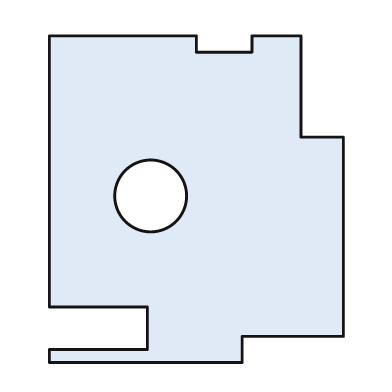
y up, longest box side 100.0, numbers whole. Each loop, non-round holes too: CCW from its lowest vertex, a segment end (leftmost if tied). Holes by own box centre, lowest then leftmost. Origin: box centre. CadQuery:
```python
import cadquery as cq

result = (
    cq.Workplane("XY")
    .moveTo(-45.0, -50.0)
    .lineTo(14.0, -50.0)
    .lineTo(14.0, -42.0)
    .lineTo(45.0, -42.0)
    .lineTo(45.0, 19.0)
    .lineTo(32.0, 19.0)
    .lineTo(32.0, 50.0)
    .lineTo(17.0, 50.0)
    .lineTo(17.0, 45.0)
    .lineTo(0.0, 45.0)
    .lineTo(0.0, 50.0)
    .lineTo(-45.0, 50.0)
    .lineTo(-45.0, -33.0)
    .lineTo(-15.0, -33.0)
    .lineTo(-15.0, -46.0)
    .lineTo(-45.0, -46.0)
    .close()
    .moveTo(-14.0, 1.0)
    .circle(11.0)
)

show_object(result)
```